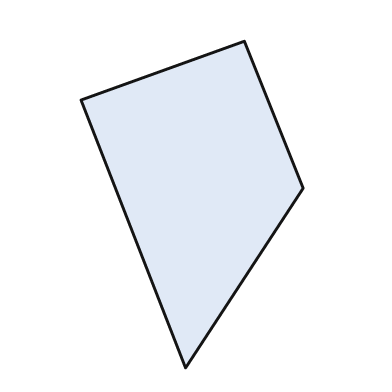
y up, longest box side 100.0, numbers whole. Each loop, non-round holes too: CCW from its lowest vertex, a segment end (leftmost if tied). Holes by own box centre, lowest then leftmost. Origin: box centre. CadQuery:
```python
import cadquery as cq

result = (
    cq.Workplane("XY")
    .moveTo(-2.0, -50.0)
    .lineTo(34.0, 5.0)
    .lineTo(16.0, 50.0)
    .lineTo(-34.0, 32.0)
    .close()
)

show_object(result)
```